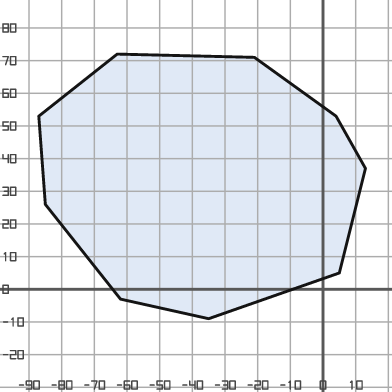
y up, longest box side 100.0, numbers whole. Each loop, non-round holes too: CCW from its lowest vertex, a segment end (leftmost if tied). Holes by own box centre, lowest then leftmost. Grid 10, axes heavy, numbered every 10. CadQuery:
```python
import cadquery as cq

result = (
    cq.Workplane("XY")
    .moveTo(-35.0, -9.0)
    .lineTo(5.0, 5.0)
    .lineTo(13.0, 37.0)
    .lineTo(4.0, 53.0)
    .lineTo(-21.0, 71.0)
    .lineTo(-63.0, 72.0)
    .lineTo(-87.0, 53.0)
    .lineTo(-85.0, 26.0)
    .lineTo(-62.0, -3.0)
    .close()
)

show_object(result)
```